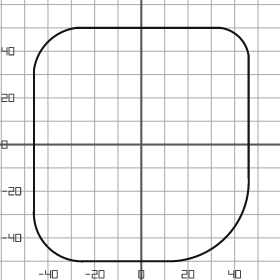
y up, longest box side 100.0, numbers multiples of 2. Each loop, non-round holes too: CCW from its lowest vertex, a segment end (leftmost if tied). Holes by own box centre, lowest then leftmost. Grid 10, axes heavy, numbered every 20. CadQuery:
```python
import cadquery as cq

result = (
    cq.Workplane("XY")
    .moveTo(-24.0, -50.0)
    .lineTo(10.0, -50.0)
    .threePointArc((36.0, -40.0), (46.0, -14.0))
    .lineTo(46.0, 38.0)
    .threePointArc((42.0, 46.0), (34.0, 50.0))
    .lineTo(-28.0, 50.0)
    .threePointArc((-40.0, 44.0), (-46.0, 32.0))
    .lineTo(-46.0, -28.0)
    .threePointArc((-40.0, -44.0), (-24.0, -50.0))
    .close()
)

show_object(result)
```